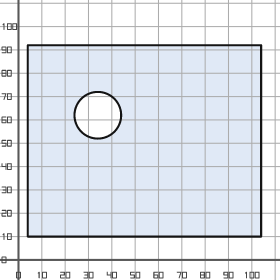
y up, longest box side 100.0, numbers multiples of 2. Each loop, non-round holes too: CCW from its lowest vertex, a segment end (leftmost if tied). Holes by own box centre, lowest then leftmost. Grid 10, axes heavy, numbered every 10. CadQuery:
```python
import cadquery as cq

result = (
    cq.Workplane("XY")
    .moveTo(4.0, 10.0)
    .lineTo(104.0, 10.0)
    .lineTo(104.0, 92.0)
    .lineTo(4.0, 92.0)
    .close()
    .moveTo(34.0, 62.0)
    .circle(10.0)
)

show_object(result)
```